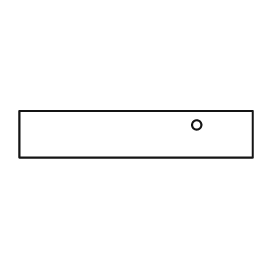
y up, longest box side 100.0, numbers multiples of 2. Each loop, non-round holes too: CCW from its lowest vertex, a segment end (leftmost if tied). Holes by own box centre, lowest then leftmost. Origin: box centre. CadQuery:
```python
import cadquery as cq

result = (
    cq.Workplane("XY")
    .moveTo(-50.0, -10.0)
    .lineTo(50.0, -10.0)
    .lineTo(50.0, 10.0)
    .lineTo(-50.0, 10.0)
    .close()
    .moveTo(26.0, 4.0)
    .circle(2.0)
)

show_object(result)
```